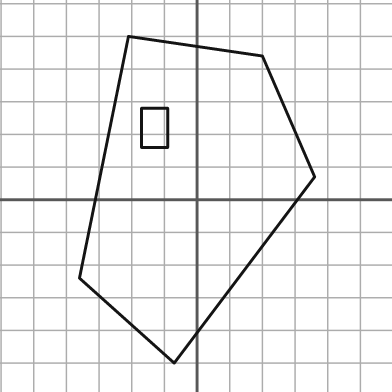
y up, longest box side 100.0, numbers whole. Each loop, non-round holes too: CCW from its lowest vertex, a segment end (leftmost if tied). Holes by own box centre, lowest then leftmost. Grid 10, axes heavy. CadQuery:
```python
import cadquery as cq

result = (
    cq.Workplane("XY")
    .moveTo(-7.0, -50.0)
    .lineTo(36.0, 7.0)
    .lineTo(20.0, 44.0)
    .lineTo(-21.0, 50.0)
    .lineTo(-36.0, -24.0)
    .close()
    .moveTo(-17.0, 16.0)
    .lineTo(-9.0, 16.0)
    .lineTo(-9.0, 28.0)
    .lineTo(-17.0, 28.0)
    .close()
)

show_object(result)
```